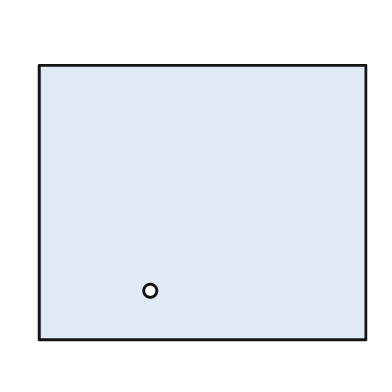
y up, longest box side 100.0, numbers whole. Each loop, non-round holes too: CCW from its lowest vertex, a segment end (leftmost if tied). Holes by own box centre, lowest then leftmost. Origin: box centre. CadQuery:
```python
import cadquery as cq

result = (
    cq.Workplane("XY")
    .moveTo(-50.0, -42.0)
    .lineTo(50.0, -42.0)
    .lineTo(50.0, 42.0)
    .lineTo(-50.0, 42.0)
    .close()
    .moveTo(-16.0, -27.0)
    .circle(2.0)
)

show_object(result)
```